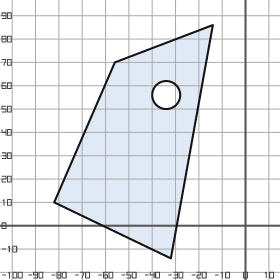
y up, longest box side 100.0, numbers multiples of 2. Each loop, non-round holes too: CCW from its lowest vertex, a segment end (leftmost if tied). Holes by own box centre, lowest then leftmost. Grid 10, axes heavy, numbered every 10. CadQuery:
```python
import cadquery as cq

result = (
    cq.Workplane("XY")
    .moveTo(-32.0, -14.0)
    .lineTo(-14.0, 86.0)
    .lineTo(-56.0, 70.0)
    .lineTo(-82.0, 10.0)
    .close()
    .moveTo(-34.0, 56.0)
    .circle(6.0)
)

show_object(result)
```